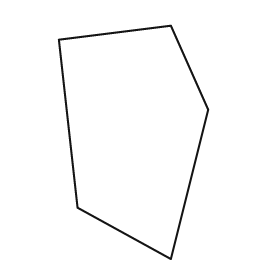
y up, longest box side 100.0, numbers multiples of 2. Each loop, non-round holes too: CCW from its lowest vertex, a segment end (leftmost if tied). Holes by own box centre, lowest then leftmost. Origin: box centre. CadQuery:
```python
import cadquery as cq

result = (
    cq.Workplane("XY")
    .moveTo(16.0, -50.0)
    .lineTo(32.0, 14.0)
    .lineTo(16.0, 50.0)
    .lineTo(-32.0, 44.0)
    .lineTo(-24.0, -28.0)
    .close()
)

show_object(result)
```